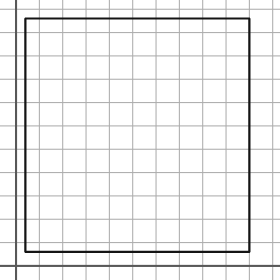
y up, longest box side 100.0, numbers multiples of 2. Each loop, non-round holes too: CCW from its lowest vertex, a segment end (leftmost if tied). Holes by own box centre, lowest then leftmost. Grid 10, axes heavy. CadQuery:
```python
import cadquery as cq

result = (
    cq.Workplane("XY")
    .moveTo(4.0, 6.0)
    .lineTo(100.0, 6.0)
    .lineTo(100.0, 106.0)
    .lineTo(4.0, 106.0)
    .close()
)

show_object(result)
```